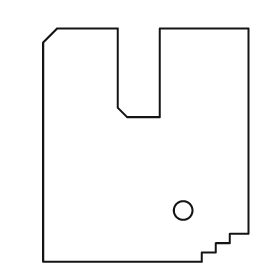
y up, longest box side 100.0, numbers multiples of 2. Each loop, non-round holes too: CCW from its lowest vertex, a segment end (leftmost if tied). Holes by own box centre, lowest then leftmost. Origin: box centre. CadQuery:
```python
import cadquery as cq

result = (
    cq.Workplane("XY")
    .moveTo(-44.0, -50.0)
    .lineTo(24.0, -50.0)
    .lineTo(24.0, -46.0)
    .lineTo(30.0, -46.0)
    .lineTo(30.0, -42.0)
    .lineTo(36.0, -42.0)
    .lineTo(36.0, -38.0)
    .lineTo(44.0, -38.0)
    .lineTo(44.0, 50.0)
    .lineTo(6.0, 50.0)
    .lineTo(6.0, 12.0)
    .lineTo(-8.0, 12.0)
    .lineTo(-12.0, 16.0)
    .lineTo(-12.0, 50.0)
    .lineTo(-38.0, 50.0)
    .lineTo(-44.0, 44.0)
    .close()
    .moveTo(16.0, -28.0)
    .circle(4.0)
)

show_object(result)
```